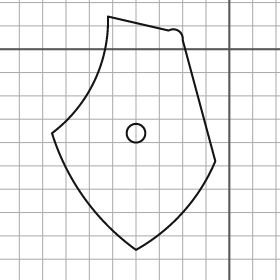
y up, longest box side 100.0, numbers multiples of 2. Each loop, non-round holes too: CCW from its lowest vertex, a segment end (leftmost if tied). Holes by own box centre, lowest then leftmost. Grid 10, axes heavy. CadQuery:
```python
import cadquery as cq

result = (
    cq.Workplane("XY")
    .moveTo(-40.0, -86.0)
    .threePointArc((-20.0, -70.0), (-6.0, -48.0))
    .lineTo(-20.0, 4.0)
    .threePointArc((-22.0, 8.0), (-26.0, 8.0))
    .lineTo(-52.0, 14.0)
    .threePointArc((-58.0, -14.0), (-76.0, -36.0))
    .threePointArc((-62.0, -64.0), (-40.0, -86.0))
    .close()
    .moveTo(-40.0, -36.0)
    .circle(4.0)
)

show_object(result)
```